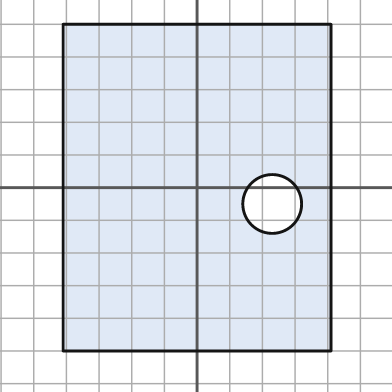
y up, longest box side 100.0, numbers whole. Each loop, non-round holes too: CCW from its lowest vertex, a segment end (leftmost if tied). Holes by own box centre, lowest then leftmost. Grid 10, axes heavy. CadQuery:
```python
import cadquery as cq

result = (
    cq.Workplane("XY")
    .moveTo(-41.0, -50.0)
    .lineTo(41.0, -50.0)
    .lineTo(41.0, 50.0)
    .lineTo(-41.0, 50.0)
    .close()
    .moveTo(23.0, -5.0)
    .circle(9.0)
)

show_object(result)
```